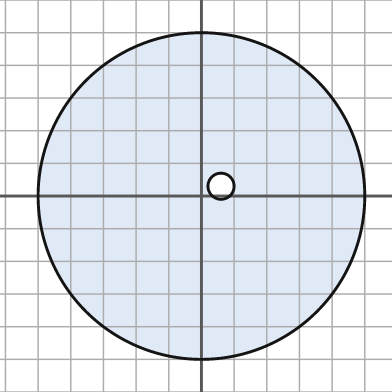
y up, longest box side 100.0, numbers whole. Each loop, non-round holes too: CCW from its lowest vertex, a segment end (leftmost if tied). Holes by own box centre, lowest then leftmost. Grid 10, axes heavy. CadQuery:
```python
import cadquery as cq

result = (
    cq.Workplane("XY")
    .moveTo(0.0, 0.0)
    .circle(50.0)
    .moveTo(6.0, 3.0)
    .circle(4.0)
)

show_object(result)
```